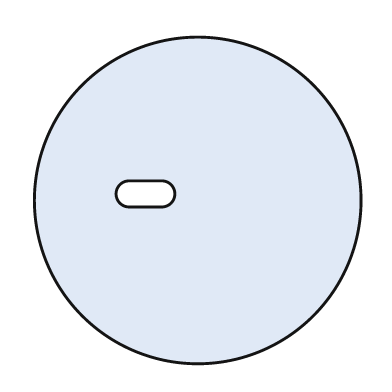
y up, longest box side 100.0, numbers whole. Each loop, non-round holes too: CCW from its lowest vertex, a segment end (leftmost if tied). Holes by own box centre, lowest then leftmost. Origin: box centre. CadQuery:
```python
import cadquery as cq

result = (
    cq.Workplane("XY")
    .moveTo(0.0, 0.0)
    .circle(50.0)
    .moveTo(-21.0, -2.0)
    .lineTo(-11.0, -2.0)
    .threePointArc((-7.0, 2.0), (-11.0, 6.0))
    .lineTo(-21.0, 6.0)
    .threePointArc((-25.0, 2.0), (-21.0, -2.0))
    .close()
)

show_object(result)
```